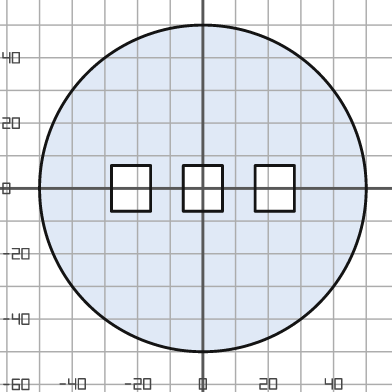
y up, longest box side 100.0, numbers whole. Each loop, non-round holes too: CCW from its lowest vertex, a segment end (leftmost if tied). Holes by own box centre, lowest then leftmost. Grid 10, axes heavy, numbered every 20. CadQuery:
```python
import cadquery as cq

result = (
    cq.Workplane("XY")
    .moveTo(0.0, 0.0)
    .circle(50.0)
    .moveTo(-28.0, -7.0)
    .lineTo(-16.0, -7.0)
    .lineTo(-16.0, 7.0)
    .lineTo(-28.0, 7.0)
    .close()
    .moveTo(-6.0, -7.0)
    .lineTo(6.0, -7.0)
    .lineTo(6.0, 7.0)
    .lineTo(-6.0, 7.0)
    .close()
    .moveTo(16.0, -7.0)
    .lineTo(28.0, -7.0)
    .lineTo(28.0, 7.0)
    .lineTo(16.0, 7.0)
    .close()
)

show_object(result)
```